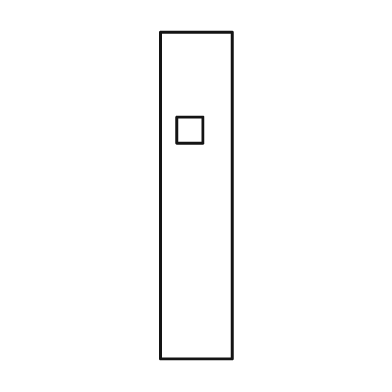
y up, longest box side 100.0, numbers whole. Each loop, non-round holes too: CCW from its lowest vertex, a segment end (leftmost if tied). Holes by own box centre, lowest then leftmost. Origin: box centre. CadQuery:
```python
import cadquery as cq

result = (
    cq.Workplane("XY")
    .moveTo(-11.0, -50.0)
    .lineTo(11.0, -50.0)
    .lineTo(11.0, 50.0)
    .lineTo(-11.0, 50.0)
    .close()
    .moveTo(-6.0, 16.0)
    .lineTo(2.0, 16.0)
    .lineTo(2.0, 24.0)
    .lineTo(-6.0, 24.0)
    .close()
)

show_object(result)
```